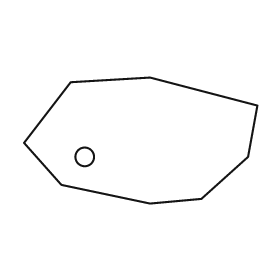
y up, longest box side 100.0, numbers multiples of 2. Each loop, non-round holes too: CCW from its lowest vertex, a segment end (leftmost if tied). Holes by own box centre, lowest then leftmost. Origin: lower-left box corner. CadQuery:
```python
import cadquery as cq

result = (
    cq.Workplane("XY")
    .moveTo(54.0, 0.0)
    .lineTo(76.0, 2.0)
    .lineTo(96.0, 20.0)
    .lineTo(100.0, 42.0)
    .lineTo(54.0, 54.0)
    .lineTo(20.0, 52.0)
    .lineTo(0.0, 26.0)
    .lineTo(16.0, 8.0)
    .close()
    .moveTo(26.0, 20.0)
    .circle(4.0)
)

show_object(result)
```